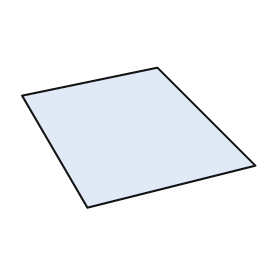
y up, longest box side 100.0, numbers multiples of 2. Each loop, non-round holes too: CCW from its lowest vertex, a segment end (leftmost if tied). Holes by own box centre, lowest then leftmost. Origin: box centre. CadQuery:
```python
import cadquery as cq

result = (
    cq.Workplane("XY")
    .moveTo(-22.0, -30.0)
    .lineTo(50.0, -12.0)
    .lineTo(8.0, 30.0)
    .lineTo(-50.0, 18.0)
    .close()
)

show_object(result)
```